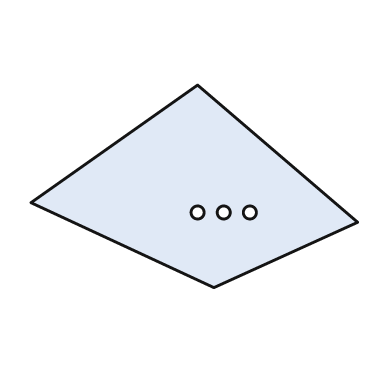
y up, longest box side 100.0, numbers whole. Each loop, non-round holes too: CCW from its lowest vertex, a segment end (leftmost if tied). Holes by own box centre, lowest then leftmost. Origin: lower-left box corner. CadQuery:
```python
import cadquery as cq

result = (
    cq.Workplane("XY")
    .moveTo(56.0, 0.0)
    .lineTo(100.0, 20.0)
    .lineTo(51.0, 62.0)
    .lineTo(0.0, 26.0)
    .close()
    .moveTo(51.0, 23.0)
    .circle(2.0)
    .moveTo(59.0, 23.0)
    .circle(2.0)
    .moveTo(67.0, 23.0)
    .circle(2.0)
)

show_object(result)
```